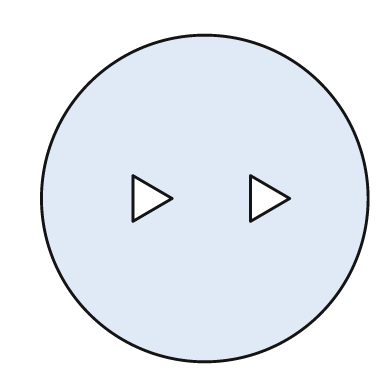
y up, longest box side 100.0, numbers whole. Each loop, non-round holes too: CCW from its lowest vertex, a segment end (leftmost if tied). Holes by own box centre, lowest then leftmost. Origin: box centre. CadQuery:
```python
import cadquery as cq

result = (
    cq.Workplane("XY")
    .moveTo(0.0, 0.0)
    .circle(50.0)
    .moveTo(-22.0, -7.0)
    .lineTo(-10.0, 0.0)
    .lineTo(-22.0, 7.0)
    .close()
    .moveTo(14.0, -7.0)
    .lineTo(26.0, 0.0)
    .lineTo(14.0, 7.0)
    .close()
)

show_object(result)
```